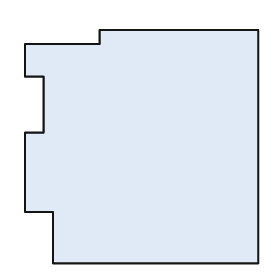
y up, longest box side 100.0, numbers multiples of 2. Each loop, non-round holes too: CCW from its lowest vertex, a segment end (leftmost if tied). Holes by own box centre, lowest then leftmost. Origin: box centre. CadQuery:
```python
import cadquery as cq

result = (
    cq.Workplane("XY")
    .moveTo(-38.0, -50.0)
    .lineTo(50.0, -50.0)
    .lineTo(50.0, 50.0)
    .lineTo(-18.0, 50.0)
    .lineTo(-18.0, 44.0)
    .lineTo(-50.0, 44.0)
    .lineTo(-50.0, 30.0)
    .lineTo(-42.0, 30.0)
    .lineTo(-42.0, 6.0)
    .lineTo(-50.0, 6.0)
    .lineTo(-50.0, -28.0)
    .lineTo(-38.0, -28.0)
    .close()
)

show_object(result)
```